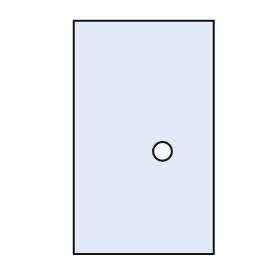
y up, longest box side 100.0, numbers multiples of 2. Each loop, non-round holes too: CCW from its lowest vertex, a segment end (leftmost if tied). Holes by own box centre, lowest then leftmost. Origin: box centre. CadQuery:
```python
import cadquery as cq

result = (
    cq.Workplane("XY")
    .moveTo(-30.0, -50.0)
    .lineTo(30.0, -50.0)
    .lineTo(30.0, 50.0)
    .lineTo(-30.0, 50.0)
    .close()
    .moveTo(8.0, -6.0)
    .circle(4.0)
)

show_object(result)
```